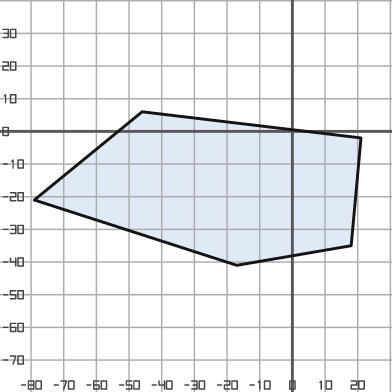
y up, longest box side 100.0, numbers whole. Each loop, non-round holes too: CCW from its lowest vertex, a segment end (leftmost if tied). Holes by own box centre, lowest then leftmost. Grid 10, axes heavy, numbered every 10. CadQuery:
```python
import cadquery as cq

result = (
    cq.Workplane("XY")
    .moveTo(-17.0, -41.0)
    .lineTo(18.0, -35.0)
    .lineTo(21.0, -2.0)
    .lineTo(-46.0, 6.0)
    .lineTo(-79.0, -21.0)
    .close()
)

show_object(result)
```